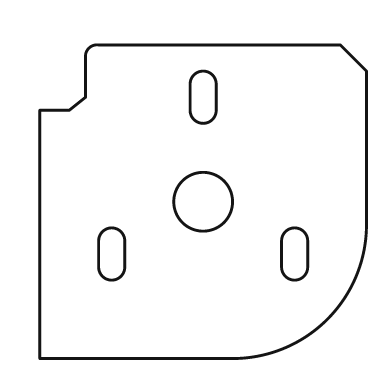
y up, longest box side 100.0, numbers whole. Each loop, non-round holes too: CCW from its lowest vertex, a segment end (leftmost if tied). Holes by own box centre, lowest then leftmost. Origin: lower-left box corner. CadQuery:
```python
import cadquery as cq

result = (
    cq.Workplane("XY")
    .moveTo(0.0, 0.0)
    .lineTo(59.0, 0.0)
    .threePointArc((88.0, 12.0), (100.0, 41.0))
    .lineTo(100.0, 88.0)
    .lineTo(92.0, 96.0)
    .lineTo(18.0, 96.0)
    .threePointArc((15.0, 95.0), (14.0, 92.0))
    .lineTo(14.0, 80.0)
    .lineTo(9.0, 76.0)
    .lineTo(0.0, 76.0)
    .close()
    .moveTo(18.0, 28.0)
    .threePointArc((22.0, 24.0), (26.0, 28.0))
    .lineTo(26.0, 36.0)
    .threePointArc((22.0, 40.0), (18.0, 36.0))
    .close()
    .moveTo(74.0, 28.0)
    .threePointArc((78.0, 24.0), (82.0, 28.0))
    .lineTo(82.0, 36.0)
    .threePointArc((78.0, 40.0), (74.0, 36.0))
    .close()
    .moveTo(50.0, 48.0)
    .circle(9.0)
    .moveTo(46.0, 76.0)
    .threePointArc((50.0, 72.0), (54.0, 76.0))
    .lineTo(54.0, 84.0)
    .threePointArc((50.0, 88.0), (46.0, 84.0))
    .close()
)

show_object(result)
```